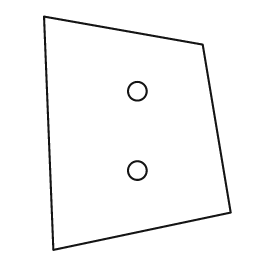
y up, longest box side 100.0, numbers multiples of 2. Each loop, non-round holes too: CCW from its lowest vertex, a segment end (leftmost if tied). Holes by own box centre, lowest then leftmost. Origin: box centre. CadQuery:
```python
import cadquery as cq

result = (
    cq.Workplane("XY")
    .moveTo(-36.0, -50.0)
    .lineTo(40.0, -34.0)
    .lineTo(28.0, 38.0)
    .lineTo(-40.0, 50.0)
    .close()
    .moveTo(0.0, -16.0)
    .circle(4.0)
    .moveTo(0.0, 18.0)
    .circle(4.0)
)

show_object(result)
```